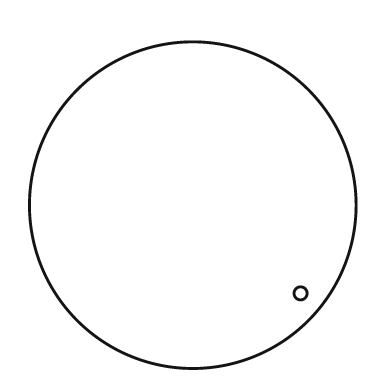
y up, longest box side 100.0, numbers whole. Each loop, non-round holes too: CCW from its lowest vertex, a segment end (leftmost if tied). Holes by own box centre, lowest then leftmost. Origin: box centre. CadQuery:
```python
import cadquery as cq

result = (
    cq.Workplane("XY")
    .moveTo(0.0, 0.0)
    .circle(50.0)
    .moveTo(33.0, -27.0)
    .circle(2.0)
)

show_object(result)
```